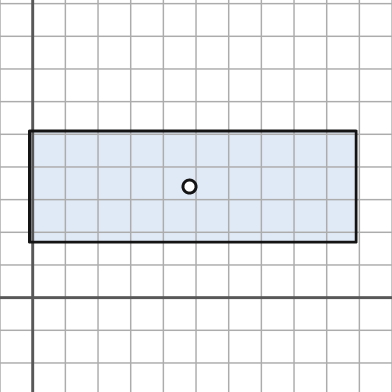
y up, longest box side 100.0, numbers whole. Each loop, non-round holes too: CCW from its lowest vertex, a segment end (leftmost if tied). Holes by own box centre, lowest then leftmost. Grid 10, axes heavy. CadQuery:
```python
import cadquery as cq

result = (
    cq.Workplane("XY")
    .moveTo(-1.0, 17.0)
    .lineTo(99.0, 17.0)
    .lineTo(99.0, 51.0)
    .lineTo(-1.0, 51.0)
    .close()
    .moveTo(48.0, 34.0)
    .circle(2.0)
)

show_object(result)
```